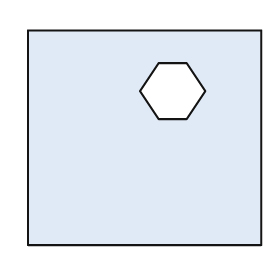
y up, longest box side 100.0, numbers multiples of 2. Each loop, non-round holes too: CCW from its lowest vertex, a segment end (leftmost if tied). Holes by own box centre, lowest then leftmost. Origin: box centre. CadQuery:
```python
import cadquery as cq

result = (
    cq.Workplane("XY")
    .moveTo(-50.0, -46.0)
    .lineTo(50.0, -46.0)
    .lineTo(50.0, 46.0)
    .lineTo(-50.0, 46.0)
    .close()
    .moveTo(6.0, 8.0)
    .lineTo(18.0, 8.0)
    .lineTo(26.0, 20.0)
    .lineTo(18.0, 32.0)
    .lineTo(6.0, 32.0)
    .lineTo(-2.0, 20.0)
    .close()
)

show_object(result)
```